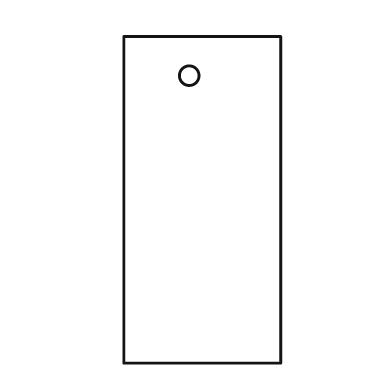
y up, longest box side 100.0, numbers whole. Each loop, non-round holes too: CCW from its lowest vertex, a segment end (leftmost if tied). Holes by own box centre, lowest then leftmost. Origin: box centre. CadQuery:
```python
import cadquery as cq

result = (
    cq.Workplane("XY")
    .moveTo(-24.0, -50.0)
    .lineTo(24.0, -50.0)
    .lineTo(24.0, 50.0)
    .lineTo(-24.0, 50.0)
    .close()
    .moveTo(-4.0, 38.0)
    .circle(3.0)
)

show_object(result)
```